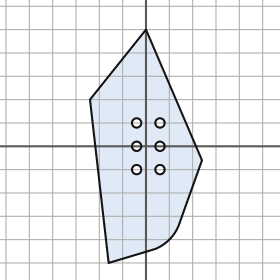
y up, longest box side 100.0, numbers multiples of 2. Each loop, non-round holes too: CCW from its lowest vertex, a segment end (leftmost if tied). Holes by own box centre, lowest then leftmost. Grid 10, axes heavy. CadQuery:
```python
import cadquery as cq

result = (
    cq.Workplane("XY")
    .moveTo(-16.0, -50.0)
    .lineTo(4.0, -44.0)
    .threePointArc((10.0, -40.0), (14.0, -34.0))
    .lineTo(24.0, -6.0)
    .lineTo(0.0, 50.0)
    .lineTo(-24.0, 20.0)
    .close()
    .moveTo(-4.0, -10.0)
    .circle(2.0)
    .moveTo(6.0, -10.0)
    .circle(2.0)
    .moveTo(-4.0, 0.0)
    .circle(2.0)
    .moveTo(6.0, 0.0)
    .circle(2.0)
    .moveTo(-4.0, 10.0)
    .circle(2.0)
    .moveTo(6.0, 10.0)
    .circle(2.0)
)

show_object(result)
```